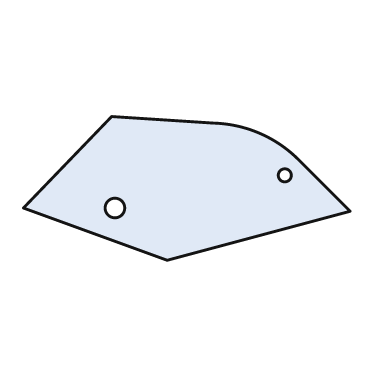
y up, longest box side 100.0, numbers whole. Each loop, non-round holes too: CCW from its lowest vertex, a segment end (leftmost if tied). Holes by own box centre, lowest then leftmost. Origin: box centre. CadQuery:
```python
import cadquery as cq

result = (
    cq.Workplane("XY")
    .moveTo(-6.0, -22.0)
    .lineTo(50.0, -7.0)
    .lineTo(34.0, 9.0)
    .threePointArc((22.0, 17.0), (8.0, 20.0))
    .lineTo(-23.0, 22.0)
    .lineTo(-50.0, -6.0)
    .close()
    .moveTo(-22.0, -6.0)
    .circle(3.0)
    .moveTo(30.0, 4.0)
    .circle(2.0)
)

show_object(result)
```